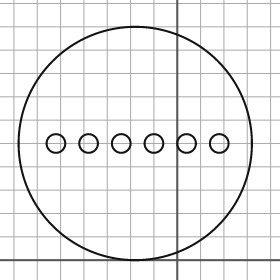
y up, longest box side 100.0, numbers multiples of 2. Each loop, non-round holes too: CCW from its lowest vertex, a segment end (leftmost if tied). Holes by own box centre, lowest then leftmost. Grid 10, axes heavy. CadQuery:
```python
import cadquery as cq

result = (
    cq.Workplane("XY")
    .moveTo(-18.0, 50.0)
    .circle(50.0)
    .moveTo(-52.0, 50.0)
    .circle(4.0)
    .moveTo(-38.0, 50.0)
    .circle(4.0)
    .moveTo(-24.0, 50.0)
    .circle(4.0)
    .moveTo(-10.0, 50.0)
    .circle(4.0)
    .moveTo(4.0, 50.0)
    .circle(4.0)
    .moveTo(18.0, 50.0)
    .circle(4.0)
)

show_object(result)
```